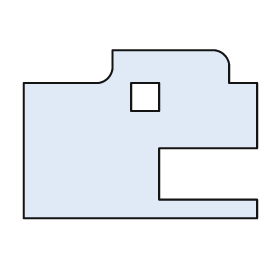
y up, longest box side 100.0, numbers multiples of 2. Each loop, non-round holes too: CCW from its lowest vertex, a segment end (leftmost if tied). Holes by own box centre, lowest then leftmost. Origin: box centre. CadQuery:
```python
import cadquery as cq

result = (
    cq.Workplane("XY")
    .moveTo(-50.0, -36.0)
    .lineTo(50.0, -36.0)
    .lineTo(50.0, -28.0)
    .lineTo(8.0, -28.0)
    .lineTo(8.0, -6.0)
    .lineTo(50.0, -6.0)
    .lineTo(50.0, 22.0)
    .lineTo(38.0, 22.0)
    .lineTo(38.0, 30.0)
    .threePointArc((36.0, 34.0), (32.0, 36.0))
    .lineTo(-12.0, 36.0)
    .lineTo(-12.0, 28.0)
    .threePointArc((-14.0, 24.0), (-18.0, 22.0))
    .lineTo(-50.0, 22.0)
    .close()
    .moveTo(-4.0, 10.0)
    .lineTo(8.0, 10.0)
    .lineTo(8.0, 22.0)
    .lineTo(-4.0, 22.0)
    .close()
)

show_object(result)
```